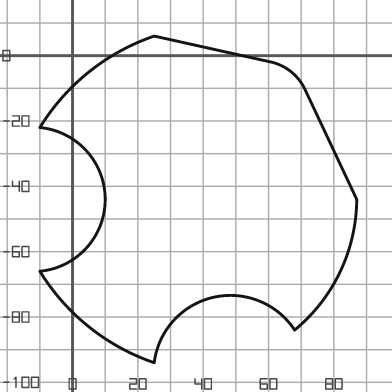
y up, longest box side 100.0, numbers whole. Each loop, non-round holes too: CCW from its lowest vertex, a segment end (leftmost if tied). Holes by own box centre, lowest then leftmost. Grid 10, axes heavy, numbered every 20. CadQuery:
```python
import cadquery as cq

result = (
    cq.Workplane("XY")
    .moveTo(25.0, -94.0)
    .threePointArc((43.0, -74.0), (68.0, -84.0))
    .threePointArc((82.0, -66.0), (87.0, -44.0))
    .lineTo(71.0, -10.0)
    .threePointArc((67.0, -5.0), (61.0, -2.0))
    .lineTo(25.0, 6.0)
    .threePointArc((5.0, -5.0), (-10.0, -22.0))
    .threePointArc((10.0, -44.0), (-10.0, -66.0))
    .threePointArc((5.0, -83.0), (25.0, -94.0))
    .close()
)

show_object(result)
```